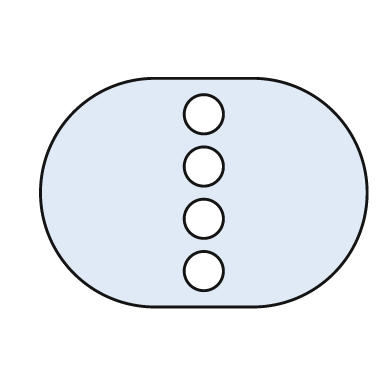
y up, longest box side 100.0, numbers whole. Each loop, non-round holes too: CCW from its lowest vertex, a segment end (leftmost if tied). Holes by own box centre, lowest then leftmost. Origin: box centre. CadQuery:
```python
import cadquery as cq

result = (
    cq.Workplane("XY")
    .moveTo(-15.0, -35.0)
    .lineTo(15.0, -35.0)
    .threePointArc((50.0, 0.0), (15.0, 35.0))
    .lineTo(-15.0, 35.0)
    .threePointArc((-50.0, 0.0), (-15.0, -35.0))
    .close()
    .moveTo(0.0, -24.0)
    .circle(6.0)
    .moveTo(0.0, -8.0)
    .circle(6.0)
    .moveTo(0.0, 8.0)
    .circle(6.0)
    .moveTo(0.0, 24.0)
    .circle(6.0)
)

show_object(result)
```